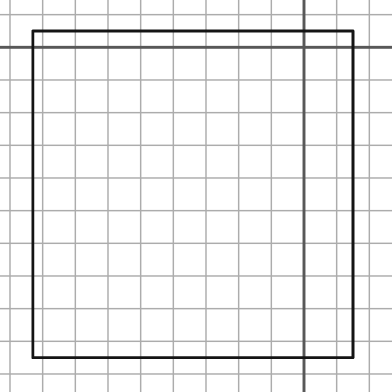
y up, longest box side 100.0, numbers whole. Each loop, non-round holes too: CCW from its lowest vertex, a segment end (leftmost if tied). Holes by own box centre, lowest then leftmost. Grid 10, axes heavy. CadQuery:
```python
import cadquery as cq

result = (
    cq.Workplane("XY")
    .moveTo(-83.0, -95.0)
    .lineTo(15.0, -95.0)
    .lineTo(15.0, 5.0)
    .lineTo(-83.0, 5.0)
    .close()
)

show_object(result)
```